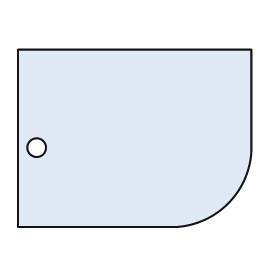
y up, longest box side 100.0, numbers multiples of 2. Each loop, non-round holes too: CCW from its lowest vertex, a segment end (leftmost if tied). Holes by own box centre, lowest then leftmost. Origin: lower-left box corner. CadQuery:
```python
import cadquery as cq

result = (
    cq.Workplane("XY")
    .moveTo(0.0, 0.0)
    .lineTo(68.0, 0.0)
    .threePointArc((90.0, 10.0), (100.0, 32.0))
    .lineTo(100.0, 76.0)
    .lineTo(0.0, 76.0)
    .close()
    .moveTo(8.0, 34.0)
    .circle(4.0)
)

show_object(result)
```